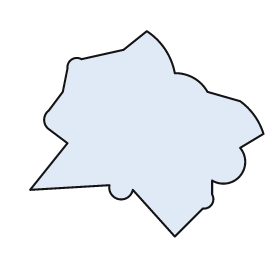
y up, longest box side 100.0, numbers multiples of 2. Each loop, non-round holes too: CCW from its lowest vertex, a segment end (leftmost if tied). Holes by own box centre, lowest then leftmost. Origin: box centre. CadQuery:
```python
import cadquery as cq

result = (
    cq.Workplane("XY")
    .moveTo(12.0, -44.0)
    .lineTo(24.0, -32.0)
    .threePointArc((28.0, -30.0), (28.0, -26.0))
    .lineTo(28.0, -20.0)
    .threePointArc((40.0, -18.0), (40.0, -6.0))
    .lineTo(50.0, 0.0)
    .threePointArc((46.0, 8.0), (40.0, 14.0))
    .lineTo(26.0, 18.0)
    .threePointArc((20.0, 24.0), (12.0, 26.0))
    .threePointArc((8.0, 36.0), (0.0, 44.0))
    .lineTo(-10.0, 36.0)
    .lineTo(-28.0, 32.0)
    .threePointArc((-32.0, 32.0), (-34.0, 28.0))
    .lineTo(-36.0, 18.0)
    .lineTo(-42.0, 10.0)
    .threePointArc((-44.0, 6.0), (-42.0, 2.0))
    .lineTo(-34.0, -4.0)
    .lineTo(-50.0, -24.0)
    .lineTo(-16.0, -22.0)
    .threePointArc((-12.0, -28.0), (-6.0, -24.0))
    .close()
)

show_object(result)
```